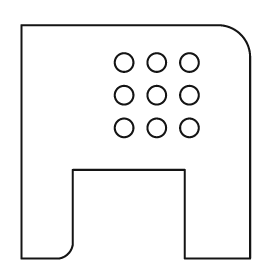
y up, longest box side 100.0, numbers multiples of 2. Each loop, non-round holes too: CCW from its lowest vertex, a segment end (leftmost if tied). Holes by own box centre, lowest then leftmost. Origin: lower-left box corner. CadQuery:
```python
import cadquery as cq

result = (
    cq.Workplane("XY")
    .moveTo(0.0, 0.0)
    .lineTo(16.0, 0.0)
    .threePointArc((20.0, 2.0), (22.0, 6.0))
    .lineTo(22.0, 38.0)
    .lineTo(70.0, 38.0)
    .lineTo(70.0, 0.0)
    .lineTo(98.0, 0.0)
    .lineTo(98.0, 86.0)
    .threePointArc((94.0, 96.0), (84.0, 100.0))
    .lineTo(0.0, 100.0)
    .close()
    .moveTo(44.0, 56.0)
    .circle(4.0)
    .moveTo(58.0, 56.0)
    .circle(4.0)
    .moveTo(72.0, 56.0)
    .circle(4.0)
    .moveTo(44.0, 70.0)
    .circle(4.0)
    .moveTo(58.0, 70.0)
    .circle(4.0)
    .moveTo(72.0, 70.0)
    .circle(4.0)
    .moveTo(44.0, 84.0)
    .circle(4.0)
    .moveTo(58.0, 84.0)
    .circle(4.0)
    .moveTo(72.0, 84.0)
    .circle(4.0)
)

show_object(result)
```